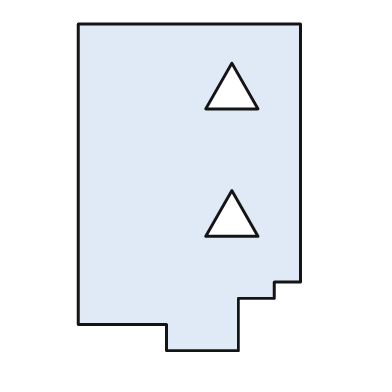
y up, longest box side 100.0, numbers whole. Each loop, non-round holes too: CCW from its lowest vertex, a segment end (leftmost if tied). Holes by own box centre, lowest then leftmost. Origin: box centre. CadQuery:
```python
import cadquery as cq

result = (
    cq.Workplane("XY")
    .moveTo(-7.0, -50.0)
    .lineTo(15.0, -50.0)
    .lineTo(15.0, -34.0)
    .lineTo(26.0, -34.0)
    .lineTo(26.0, -29.0)
    .lineTo(34.0, -29.0)
    .lineTo(34.0, 50.0)
    .lineTo(-34.0, 50.0)
    .lineTo(-34.0, -42.0)
    .lineTo(-7.0, -42.0)
    .close()
    .moveTo(5.0, -15.0)
    .lineTo(21.0, -15.0)
    .lineTo(13.0, -1.0)
    .close()
    .moveTo(5.0, 24.0)
    .lineTo(21.0, 24.0)
    .lineTo(13.0, 38.0)
    .close()
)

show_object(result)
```